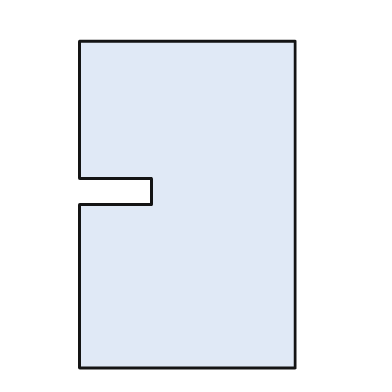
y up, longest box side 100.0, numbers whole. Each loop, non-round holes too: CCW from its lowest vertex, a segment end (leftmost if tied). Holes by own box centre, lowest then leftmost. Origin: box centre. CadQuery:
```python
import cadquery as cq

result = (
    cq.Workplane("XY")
    .moveTo(-33.0, -50.0)
    .lineTo(33.0, -50.0)
    .lineTo(33.0, 50.0)
    .lineTo(-33.0, 50.0)
    .lineTo(-33.0, 8.0)
    .lineTo(-11.0, 8.0)
    .lineTo(-11.0, 0.0)
    .lineTo(-33.0, 0.0)
    .close()
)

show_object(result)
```